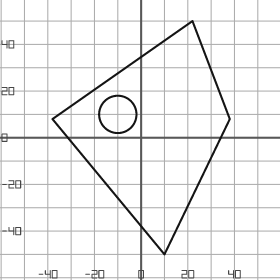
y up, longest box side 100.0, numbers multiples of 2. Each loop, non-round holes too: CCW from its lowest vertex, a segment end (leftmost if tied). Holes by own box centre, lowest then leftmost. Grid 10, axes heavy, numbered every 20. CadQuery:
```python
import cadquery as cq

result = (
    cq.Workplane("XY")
    .moveTo(10.0, -50.0)
    .lineTo(38.0, 8.0)
    .lineTo(22.0, 50.0)
    .lineTo(-38.0, 8.0)
    .close()
    .moveTo(-10.0, 10.0)
    .circle(8.0)
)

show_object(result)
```